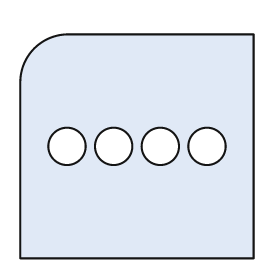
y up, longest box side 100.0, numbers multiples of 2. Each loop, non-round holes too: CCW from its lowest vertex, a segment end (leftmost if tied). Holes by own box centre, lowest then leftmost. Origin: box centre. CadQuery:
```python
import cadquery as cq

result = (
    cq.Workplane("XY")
    .moveTo(-50.0, -48.0)
    .lineTo(50.0, -48.0)
    .lineTo(50.0, 48.0)
    .lineTo(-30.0, 48.0)
    .threePointArc((-44.0, 42.0), (-50.0, 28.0))
    .close()
    .moveTo(-30.0, 0.0)
    .circle(8.0)
    .moveTo(-10.0, 0.0)
    .circle(8.0)
    .moveTo(10.0, 0.0)
    .circle(8.0)
    .moveTo(30.0, 0.0)
    .circle(8.0)
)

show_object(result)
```